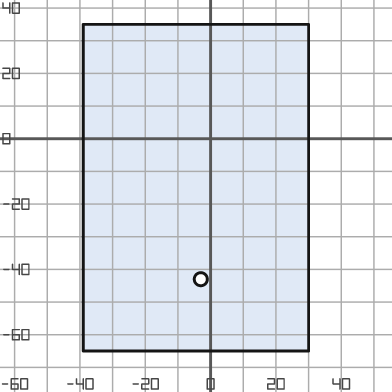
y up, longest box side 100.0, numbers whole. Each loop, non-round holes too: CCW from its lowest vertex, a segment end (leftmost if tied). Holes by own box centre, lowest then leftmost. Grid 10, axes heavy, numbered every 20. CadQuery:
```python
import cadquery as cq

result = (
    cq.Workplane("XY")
    .moveTo(-39.0, -65.0)
    .lineTo(30.0, -65.0)
    .lineTo(30.0, 35.0)
    .lineTo(-39.0, 35.0)
    .close()
    .moveTo(-3.0, -43.0)
    .circle(2.0)
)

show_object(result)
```